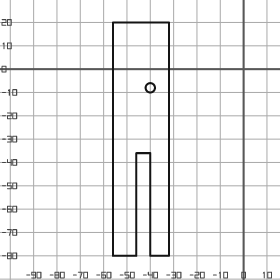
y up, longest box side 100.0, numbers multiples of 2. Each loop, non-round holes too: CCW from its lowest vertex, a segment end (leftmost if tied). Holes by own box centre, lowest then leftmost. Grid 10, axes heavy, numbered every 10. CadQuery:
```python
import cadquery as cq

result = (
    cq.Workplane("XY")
    .moveTo(-56.0, -80.0)
    .lineTo(-46.0, -80.0)
    .lineTo(-46.0, -36.0)
    .lineTo(-40.0, -36.0)
    .lineTo(-40.0, -80.0)
    .lineTo(-32.0, -80.0)
    .lineTo(-32.0, 20.0)
    .lineTo(-56.0, 20.0)
    .close()
    .moveTo(-40.0, -8.0)
    .circle(2.0)
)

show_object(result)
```